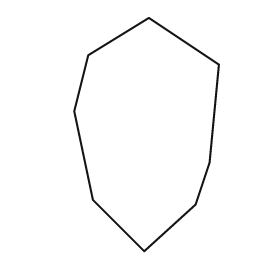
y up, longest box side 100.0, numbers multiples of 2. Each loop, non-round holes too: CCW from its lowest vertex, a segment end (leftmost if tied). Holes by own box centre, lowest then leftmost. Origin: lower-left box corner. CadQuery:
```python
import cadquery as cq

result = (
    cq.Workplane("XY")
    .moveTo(30.0, 0.0)
    .lineTo(52.0, 20.0)
    .lineTo(58.0, 38.0)
    .lineTo(62.0, 80.0)
    .lineTo(32.0, 100.0)
    .lineTo(6.0, 84.0)
    .lineTo(0.0, 60.0)
    .lineTo(8.0, 22.0)
    .close()
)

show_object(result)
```